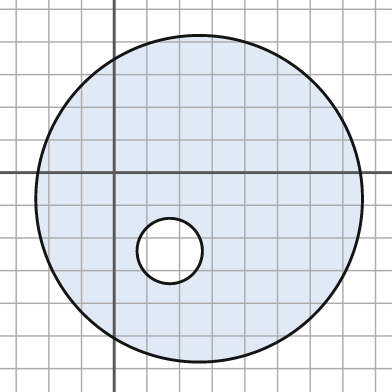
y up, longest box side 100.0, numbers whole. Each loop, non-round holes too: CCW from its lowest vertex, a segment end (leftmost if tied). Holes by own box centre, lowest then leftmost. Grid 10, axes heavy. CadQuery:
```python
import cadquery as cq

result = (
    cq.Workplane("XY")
    .moveTo(26.0, -8.0)
    .circle(50.0)
    .moveTo(17.0, -24.0)
    .circle(10.0)
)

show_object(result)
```